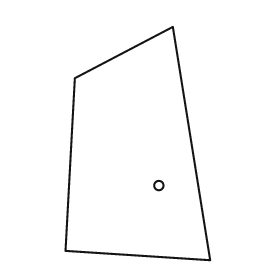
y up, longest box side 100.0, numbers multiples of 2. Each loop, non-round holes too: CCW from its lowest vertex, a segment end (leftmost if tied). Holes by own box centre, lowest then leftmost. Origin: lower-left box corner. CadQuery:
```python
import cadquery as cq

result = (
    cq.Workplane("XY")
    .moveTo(62.0, 0.0)
    .lineTo(46.0, 100.0)
    .lineTo(4.0, 78.0)
    .lineTo(0.0, 4.0)
    .close()
    .moveTo(40.0, 32.0)
    .circle(2.0)
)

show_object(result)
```